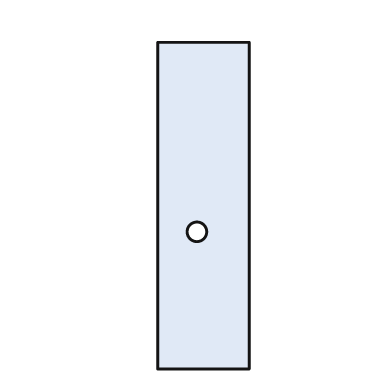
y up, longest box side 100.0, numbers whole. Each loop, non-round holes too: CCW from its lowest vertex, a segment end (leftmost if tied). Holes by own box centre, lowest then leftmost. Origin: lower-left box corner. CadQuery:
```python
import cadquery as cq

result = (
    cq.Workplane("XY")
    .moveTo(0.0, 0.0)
    .lineTo(28.0, 0.0)
    .lineTo(28.0, 100.0)
    .lineTo(0.0, 100.0)
    .close()
    .moveTo(12.0, 42.0)
    .circle(3.0)
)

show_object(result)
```